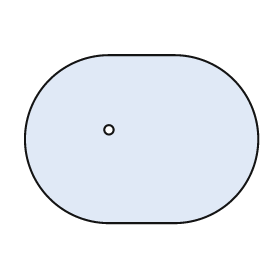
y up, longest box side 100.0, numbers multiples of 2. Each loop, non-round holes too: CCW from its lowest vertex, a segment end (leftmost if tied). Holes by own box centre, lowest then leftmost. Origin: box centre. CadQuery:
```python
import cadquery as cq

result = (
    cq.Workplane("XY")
    .moveTo(-14.0, -36.0)
    .lineTo(14.0, -36.0)
    .threePointArc((50.0, 0.0), (14.0, 36.0))
    .lineTo(-14.0, 36.0)
    .threePointArc((-50.0, 0.0), (-14.0, -36.0))
    .close()
    .moveTo(-14.0, 4.0)
    .circle(2.0)
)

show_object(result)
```